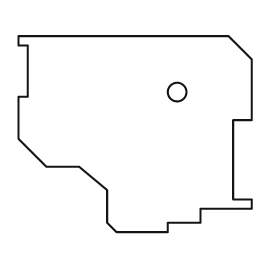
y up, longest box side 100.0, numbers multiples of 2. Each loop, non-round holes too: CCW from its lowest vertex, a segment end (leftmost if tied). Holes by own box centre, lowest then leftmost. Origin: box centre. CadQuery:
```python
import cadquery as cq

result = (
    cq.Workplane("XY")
    .moveTo(-8.0, -42.0)
    .lineTo(14.0, -42.0)
    .lineTo(14.0, -38.0)
    .lineTo(28.0, -38.0)
    .lineTo(28.0, -32.0)
    .lineTo(50.0, -32.0)
    .lineTo(50.0, -28.0)
    .lineTo(42.0, -28.0)
    .lineTo(42.0, 6.0)
    .lineTo(50.0, 6.0)
    .lineTo(50.0, 32.0)
    .lineTo(40.0, 42.0)
    .lineTo(-50.0, 42.0)
    .lineTo(-50.0, 38.0)
    .lineTo(-46.0, 38.0)
    .lineTo(-46.0, 16.0)
    .lineTo(-50.0, 16.0)
    .lineTo(-50.0, -2.0)
    .lineTo(-38.0, -14.0)
    .lineTo(-24.0, -14.0)
    .lineTo(-12.0, -24.0)
    .lineTo(-12.0, -38.0)
    .close()
    .moveTo(18.0, 18.0)
    .circle(4.0)
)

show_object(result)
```